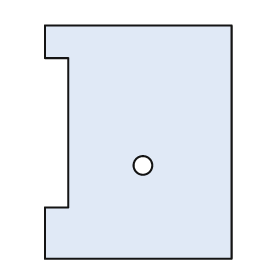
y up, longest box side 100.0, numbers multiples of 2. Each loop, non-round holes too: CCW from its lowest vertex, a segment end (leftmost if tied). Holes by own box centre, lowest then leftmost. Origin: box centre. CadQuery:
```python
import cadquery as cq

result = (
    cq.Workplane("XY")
    .moveTo(-40.0, -50.0)
    .lineTo(40.0, -50.0)
    .lineTo(40.0, 50.0)
    .lineTo(-40.0, 50.0)
    .lineTo(-40.0, 36.0)
    .lineTo(-30.0, 36.0)
    .lineTo(-30.0, -28.0)
    .lineTo(-40.0, -28.0)
    .close()
    .moveTo(2.0, -10.0)
    .circle(4.0)
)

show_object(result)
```